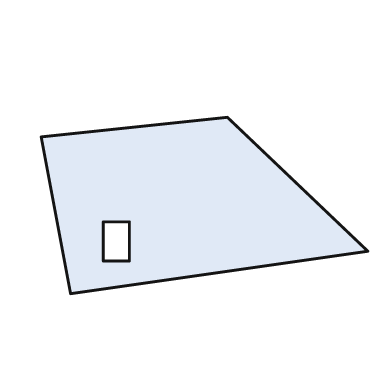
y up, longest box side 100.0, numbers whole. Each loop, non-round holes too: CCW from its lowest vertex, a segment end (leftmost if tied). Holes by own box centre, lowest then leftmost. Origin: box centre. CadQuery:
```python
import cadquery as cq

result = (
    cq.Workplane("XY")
    .moveTo(-41.0, -27.0)
    .lineTo(50.0, -14.0)
    .lineTo(7.0, 27.0)
    .lineTo(-50.0, 21.0)
    .close()
    .moveTo(-31.0, -17.0)
    .lineTo(-23.0, -17.0)
    .lineTo(-23.0, -5.0)
    .lineTo(-31.0, -5.0)
    .close()
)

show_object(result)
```